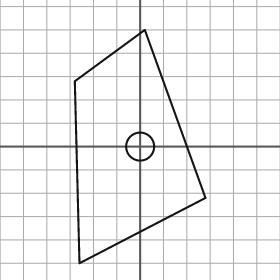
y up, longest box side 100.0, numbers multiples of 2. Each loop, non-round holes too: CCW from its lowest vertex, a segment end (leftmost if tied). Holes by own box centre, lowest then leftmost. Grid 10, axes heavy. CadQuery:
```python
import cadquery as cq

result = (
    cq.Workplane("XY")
    .moveTo(-26.0, -50.0)
    .lineTo(28.0, -22.0)
    .lineTo(2.0, 50.0)
    .lineTo(-28.0, 28.0)
    .close()
    .moveTo(0.0, 0.0)
    .circle(6.0)
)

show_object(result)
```